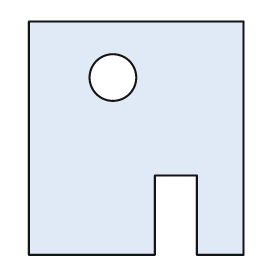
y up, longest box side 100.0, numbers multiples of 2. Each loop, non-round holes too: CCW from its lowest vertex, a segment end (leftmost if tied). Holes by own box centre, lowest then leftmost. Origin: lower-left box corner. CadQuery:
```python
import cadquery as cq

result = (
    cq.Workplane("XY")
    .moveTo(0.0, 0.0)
    .lineTo(54.0, 0.0)
    .lineTo(54.0, 34.0)
    .lineTo(72.0, 34.0)
    .lineTo(72.0, 0.0)
    .lineTo(92.0, 0.0)
    .lineTo(92.0, 100.0)
    .lineTo(0.0, 100.0)
    .close()
    .moveTo(36.0, 76.0)
    .circle(10.0)
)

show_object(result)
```